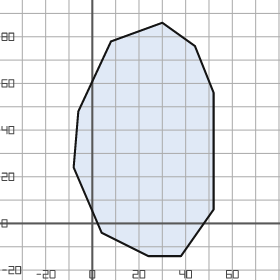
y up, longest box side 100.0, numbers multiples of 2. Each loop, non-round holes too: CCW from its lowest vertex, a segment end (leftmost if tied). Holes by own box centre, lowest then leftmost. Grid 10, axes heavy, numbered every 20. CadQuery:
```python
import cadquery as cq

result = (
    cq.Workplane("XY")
    .moveTo(24.0, -14.0)
    .lineTo(38.0, -14.0)
    .lineTo(52.0, 6.0)
    .lineTo(52.0, 56.0)
    .lineTo(44.0, 76.0)
    .lineTo(30.0, 86.0)
    .lineTo(8.0, 78.0)
    .lineTo(-6.0, 48.0)
    .lineTo(-8.0, 24.0)
    .lineTo(4.0, -4.0)
    .close()
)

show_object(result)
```